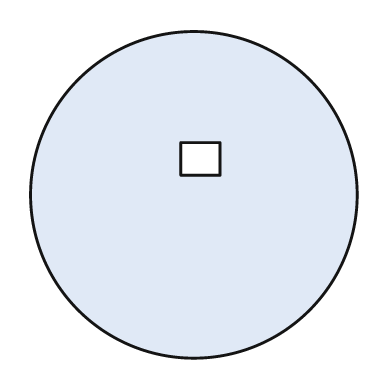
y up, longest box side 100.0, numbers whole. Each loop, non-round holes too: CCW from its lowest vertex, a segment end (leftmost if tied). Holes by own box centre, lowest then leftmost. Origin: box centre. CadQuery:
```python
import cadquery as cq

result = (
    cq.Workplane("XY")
    .moveTo(0.0, 0.0)
    .circle(50.0)
    .moveTo(-4.0, 6.0)
    .lineTo(8.0, 6.0)
    .lineTo(8.0, 16.0)
    .lineTo(-4.0, 16.0)
    .close()
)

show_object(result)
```